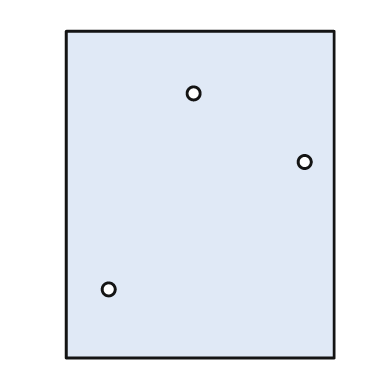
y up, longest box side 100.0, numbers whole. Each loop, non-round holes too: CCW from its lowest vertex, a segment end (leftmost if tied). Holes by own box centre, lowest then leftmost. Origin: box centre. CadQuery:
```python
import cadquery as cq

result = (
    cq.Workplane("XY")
    .moveTo(-41.0, -50.0)
    .lineTo(41.0, -50.0)
    .lineTo(41.0, 50.0)
    .lineTo(-41.0, 50.0)
    .close()
    .moveTo(-28.0, -29.0)
    .circle(2.0)
    .moveTo(32.0, 10.0)
    .circle(2.0)
    .moveTo(-2.0, 31.0)
    .circle(2.0)
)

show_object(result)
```